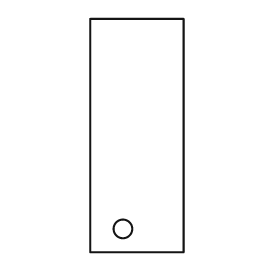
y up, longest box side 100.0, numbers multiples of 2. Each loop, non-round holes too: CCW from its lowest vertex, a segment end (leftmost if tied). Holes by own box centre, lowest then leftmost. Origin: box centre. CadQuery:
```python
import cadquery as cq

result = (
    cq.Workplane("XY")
    .moveTo(-20.0, -50.0)
    .lineTo(20.0, -50.0)
    .lineTo(20.0, 50.0)
    .lineTo(-20.0, 50.0)
    .close()
    .moveTo(-6.0, -40.0)
    .circle(4.0)
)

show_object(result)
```